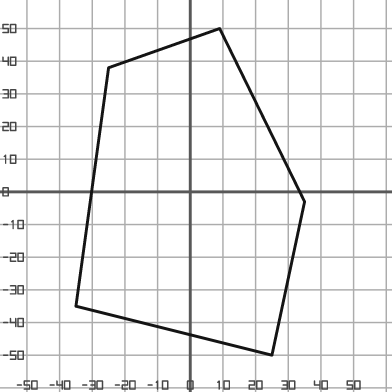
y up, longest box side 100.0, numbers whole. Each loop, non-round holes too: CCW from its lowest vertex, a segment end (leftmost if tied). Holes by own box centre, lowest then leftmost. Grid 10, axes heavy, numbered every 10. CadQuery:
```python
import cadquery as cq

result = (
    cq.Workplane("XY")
    .moveTo(25.0, -50.0)
    .lineTo(35.0, -3.0)
    .lineTo(9.0, 50.0)
    .lineTo(-25.0, 38.0)
    .lineTo(-35.0, -35.0)
    .close()
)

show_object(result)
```